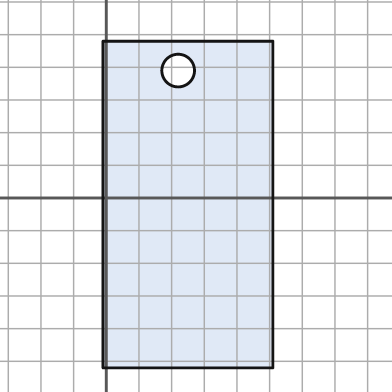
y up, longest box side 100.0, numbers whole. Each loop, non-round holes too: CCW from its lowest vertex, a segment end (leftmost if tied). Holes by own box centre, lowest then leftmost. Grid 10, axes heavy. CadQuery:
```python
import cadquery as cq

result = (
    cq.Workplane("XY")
    .moveTo(-1.0, -52.0)
    .lineTo(51.0, -52.0)
    .lineTo(51.0, 48.0)
    .lineTo(-1.0, 48.0)
    .close()
    .moveTo(22.0, 39.0)
    .circle(5.0)
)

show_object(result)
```